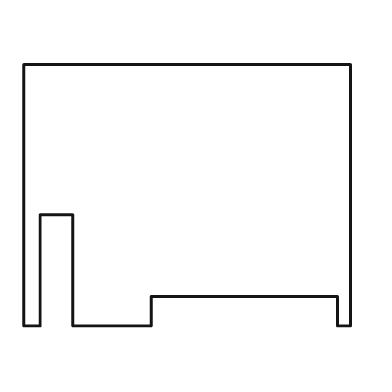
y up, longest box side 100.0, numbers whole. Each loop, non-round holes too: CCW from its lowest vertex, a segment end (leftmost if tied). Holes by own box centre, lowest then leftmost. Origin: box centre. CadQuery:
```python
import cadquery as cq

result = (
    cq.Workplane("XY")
    .moveTo(-50.0, -40.0)
    .lineTo(-45.0, -40.0)
    .lineTo(-45.0, -6.0)
    .lineTo(-35.0, -6.0)
    .lineTo(-35.0, -40.0)
    .lineTo(-11.0, -40.0)
    .lineTo(-11.0, -31.0)
    .lineTo(46.0, -31.0)
    .lineTo(46.0, -40.0)
    .lineTo(50.0, -40.0)
    .lineTo(50.0, 40.0)
    .lineTo(-50.0, 40.0)
    .close()
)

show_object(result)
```